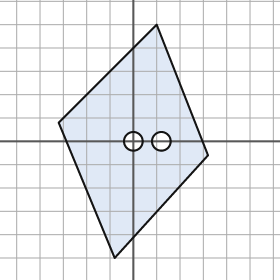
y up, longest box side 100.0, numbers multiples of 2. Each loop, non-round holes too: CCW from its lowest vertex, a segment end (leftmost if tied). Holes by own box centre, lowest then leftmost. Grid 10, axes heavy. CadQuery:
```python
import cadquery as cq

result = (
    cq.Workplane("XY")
    .moveTo(-8.0, -50.0)
    .lineTo(32.0, -6.0)
    .lineTo(10.0, 50.0)
    .lineTo(-32.0, 8.0)
    .close()
    .moveTo(0.0, 0.0)
    .circle(4.0)
    .moveTo(12.0, 0.0)
    .circle(4.0)
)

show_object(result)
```